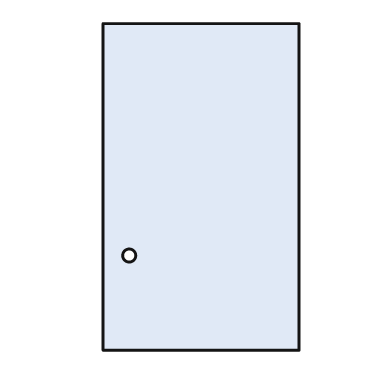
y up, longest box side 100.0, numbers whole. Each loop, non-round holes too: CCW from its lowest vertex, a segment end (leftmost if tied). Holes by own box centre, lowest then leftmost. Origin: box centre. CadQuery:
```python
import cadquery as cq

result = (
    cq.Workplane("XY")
    .moveTo(-30.0, -50.0)
    .lineTo(30.0, -50.0)
    .lineTo(30.0, 50.0)
    .lineTo(-30.0, 50.0)
    .close()
    .moveTo(-22.0, -21.0)
    .circle(2.0)
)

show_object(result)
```